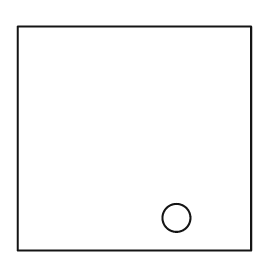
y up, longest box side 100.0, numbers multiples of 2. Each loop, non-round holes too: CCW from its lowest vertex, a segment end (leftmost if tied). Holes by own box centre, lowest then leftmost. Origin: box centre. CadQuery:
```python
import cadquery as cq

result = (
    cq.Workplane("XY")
    .moveTo(-50.0, -48.0)
    .lineTo(50.0, -48.0)
    .lineTo(50.0, 48.0)
    .lineTo(-50.0, 48.0)
    .close()
    .moveTo(18.0, -34.0)
    .circle(6.0)
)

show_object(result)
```